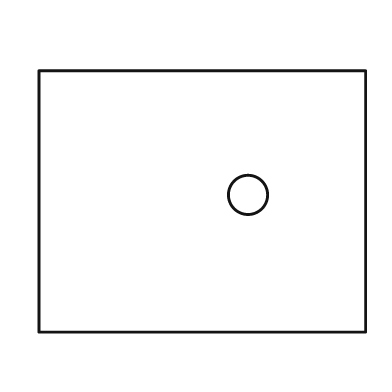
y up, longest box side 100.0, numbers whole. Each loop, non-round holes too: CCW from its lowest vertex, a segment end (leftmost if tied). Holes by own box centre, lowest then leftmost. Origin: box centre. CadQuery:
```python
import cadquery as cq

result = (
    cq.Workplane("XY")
    .moveTo(-50.0, -40.0)
    .lineTo(50.0, -40.0)
    .lineTo(50.0, 40.0)
    .lineTo(-50.0, 40.0)
    .close()
    .moveTo(14.0, 2.0)
    .circle(6.0)
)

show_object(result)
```